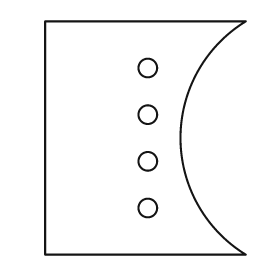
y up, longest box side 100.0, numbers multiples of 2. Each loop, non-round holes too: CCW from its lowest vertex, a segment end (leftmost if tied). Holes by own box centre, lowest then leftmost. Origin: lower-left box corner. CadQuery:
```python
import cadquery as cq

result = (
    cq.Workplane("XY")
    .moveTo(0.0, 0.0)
    .lineTo(86.0, 0.0)
    .threePointArc((58.0, 50.0), (86.0, 100.0))
    .lineTo(0.0, 100.0)
    .close()
    .moveTo(44.0, 20.0)
    .circle(4.0)
    .moveTo(44.0, 40.0)
    .circle(4.0)
    .moveTo(44.0, 60.0)
    .circle(4.0)
    .moveTo(44.0, 80.0)
    .circle(4.0)
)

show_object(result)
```